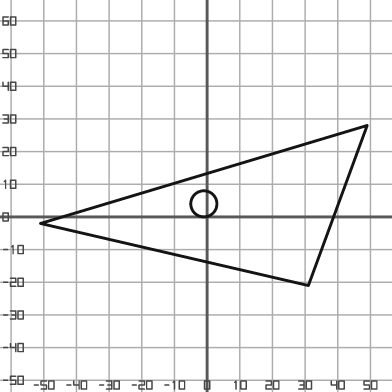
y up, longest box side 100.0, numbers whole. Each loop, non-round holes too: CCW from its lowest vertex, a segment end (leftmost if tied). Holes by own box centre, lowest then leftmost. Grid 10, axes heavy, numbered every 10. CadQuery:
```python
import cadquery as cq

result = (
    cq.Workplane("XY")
    .moveTo(31.0, -21.0)
    .lineTo(49.0, 28.0)
    .lineTo(-51.0, -2.0)
    .close()
    .moveTo(-1.0, 4.0)
    .circle(4.0)
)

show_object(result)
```